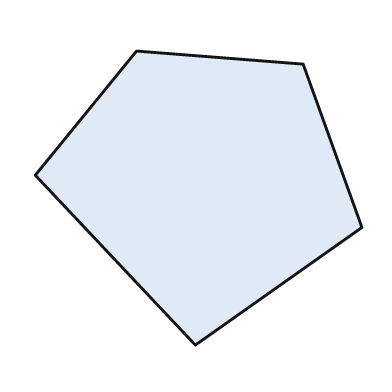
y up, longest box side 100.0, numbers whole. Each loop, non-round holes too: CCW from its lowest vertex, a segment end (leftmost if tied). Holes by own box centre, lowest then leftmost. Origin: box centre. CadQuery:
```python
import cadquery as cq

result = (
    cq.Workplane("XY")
    .moveTo(-1.0, -45.0)
    .lineTo(50.0, -9.0)
    .lineTo(32.0, 41.0)
    .lineTo(-19.0, 45.0)
    .lineTo(-50.0, 7.0)
    .close()
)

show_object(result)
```